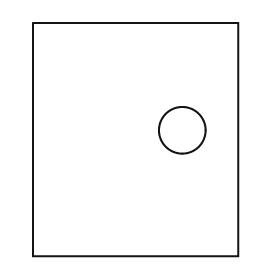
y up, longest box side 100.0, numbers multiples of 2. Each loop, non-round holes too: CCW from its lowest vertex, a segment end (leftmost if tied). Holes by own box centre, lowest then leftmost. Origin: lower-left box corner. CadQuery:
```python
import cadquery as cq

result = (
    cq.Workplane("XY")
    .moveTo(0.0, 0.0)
    .lineTo(88.0, 0.0)
    .lineTo(88.0, 100.0)
    .lineTo(0.0, 100.0)
    .close()
    .moveTo(64.0, 54.0)
    .circle(10.0)
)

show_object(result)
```